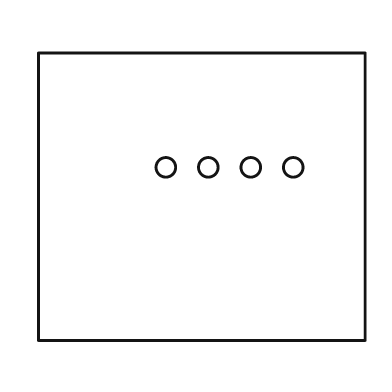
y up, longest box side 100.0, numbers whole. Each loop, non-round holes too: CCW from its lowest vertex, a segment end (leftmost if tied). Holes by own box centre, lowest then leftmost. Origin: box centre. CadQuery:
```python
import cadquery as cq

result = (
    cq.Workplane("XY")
    .moveTo(-50.0, -44.0)
    .lineTo(50.0, -44.0)
    .lineTo(50.0, 44.0)
    .lineTo(-50.0, 44.0)
    .close()
    .moveTo(-11.0, 9.0)
    .circle(3.0)
    .moveTo(2.0, 9.0)
    .circle(3.0)
    .moveTo(15.0, 9.0)
    .circle(3.0)
    .moveTo(28.0, 9.0)
    .circle(3.0)
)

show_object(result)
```